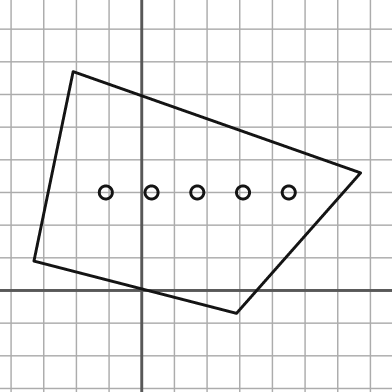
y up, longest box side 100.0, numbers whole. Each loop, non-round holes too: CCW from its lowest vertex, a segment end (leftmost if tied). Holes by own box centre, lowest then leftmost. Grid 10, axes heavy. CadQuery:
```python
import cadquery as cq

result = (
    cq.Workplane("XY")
    .moveTo(29.0, -7.0)
    .lineTo(67.0, 36.0)
    .lineTo(-21.0, 67.0)
    .lineTo(-33.0, 9.0)
    .close()
    .moveTo(-11.0, 30.0)
    .circle(2.0)
    .moveTo(3.0, 30.0)
    .circle(2.0)
    .moveTo(17.0, 30.0)
    .circle(2.0)
    .moveTo(31.0, 30.0)
    .circle(2.0)
    .moveTo(45.0, 30.0)
    .circle(2.0)
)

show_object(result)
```